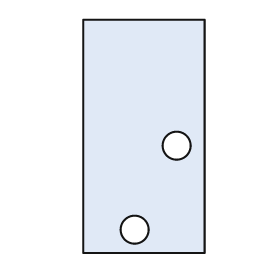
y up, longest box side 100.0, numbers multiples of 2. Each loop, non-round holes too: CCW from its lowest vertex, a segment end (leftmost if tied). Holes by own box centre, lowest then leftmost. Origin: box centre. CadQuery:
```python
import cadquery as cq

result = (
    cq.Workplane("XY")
    .moveTo(-26.0, -50.0)
    .lineTo(26.0, -50.0)
    .lineTo(26.0, 50.0)
    .lineTo(-26.0, 50.0)
    .close()
    .moveTo(-4.0, -40.0)
    .circle(6.0)
    .moveTo(14.0, -4.0)
    .circle(6.0)
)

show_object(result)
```